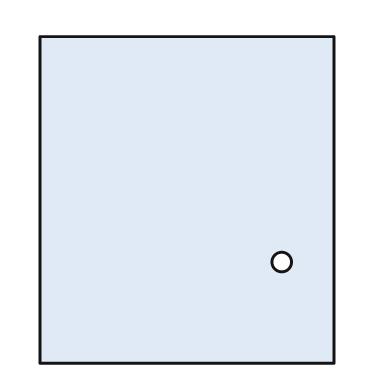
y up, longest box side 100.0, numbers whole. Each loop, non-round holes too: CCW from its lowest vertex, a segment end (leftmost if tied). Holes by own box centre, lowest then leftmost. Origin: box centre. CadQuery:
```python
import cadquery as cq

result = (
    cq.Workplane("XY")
    .moveTo(-45.0, -50.0)
    .lineTo(45.0, -50.0)
    .lineTo(45.0, 50.0)
    .lineTo(-45.0, 50.0)
    .close()
    .moveTo(29.0, -19.0)
    .circle(3.0)
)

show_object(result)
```